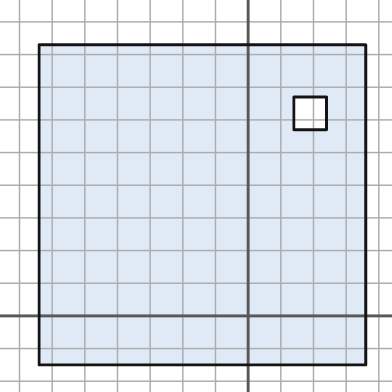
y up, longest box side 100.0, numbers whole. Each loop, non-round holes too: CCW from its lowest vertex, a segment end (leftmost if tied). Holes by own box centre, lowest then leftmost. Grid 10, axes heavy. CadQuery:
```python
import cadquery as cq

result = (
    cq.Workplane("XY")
    .moveTo(-64.0, -15.0)
    .lineTo(36.0, -15.0)
    .lineTo(36.0, 83.0)
    .lineTo(-64.0, 83.0)
    .close()
    .moveTo(14.0, 57.0)
    .lineTo(24.0, 57.0)
    .lineTo(24.0, 67.0)
    .lineTo(14.0, 67.0)
    .close()
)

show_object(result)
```